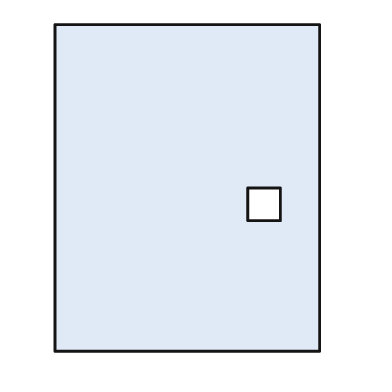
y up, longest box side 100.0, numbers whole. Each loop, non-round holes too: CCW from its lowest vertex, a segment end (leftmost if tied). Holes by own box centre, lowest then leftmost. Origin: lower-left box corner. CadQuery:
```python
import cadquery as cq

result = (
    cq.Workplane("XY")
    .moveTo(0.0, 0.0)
    .lineTo(81.0, 0.0)
    .lineTo(81.0, 100.0)
    .lineTo(0.0, 100.0)
    .close()
    .moveTo(59.0, 40.0)
    .lineTo(69.0, 40.0)
    .lineTo(69.0, 50.0)
    .lineTo(59.0, 50.0)
    .close()
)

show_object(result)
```